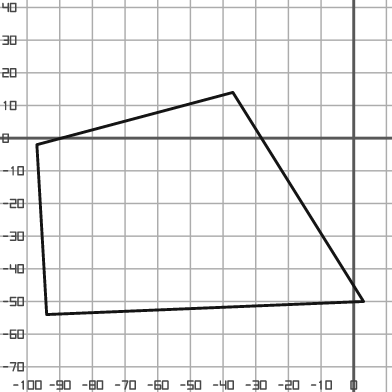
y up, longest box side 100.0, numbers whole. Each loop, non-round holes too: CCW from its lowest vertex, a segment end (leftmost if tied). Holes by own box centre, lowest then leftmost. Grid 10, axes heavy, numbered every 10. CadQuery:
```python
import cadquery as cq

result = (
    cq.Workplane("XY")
    .moveTo(-94.0, -54.0)
    .lineTo(3.0, -50.0)
    .lineTo(-37.0, 14.0)
    .lineTo(-97.0, -2.0)
    .close()
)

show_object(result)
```